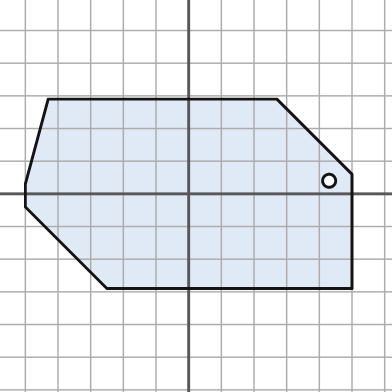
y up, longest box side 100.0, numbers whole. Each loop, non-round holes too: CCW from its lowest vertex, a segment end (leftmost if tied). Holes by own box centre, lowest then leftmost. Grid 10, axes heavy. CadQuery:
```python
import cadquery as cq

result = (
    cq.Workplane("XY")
    .moveTo(-25.0, -29.0)
    .lineTo(50.0, -29.0)
    .lineTo(50.0, 6.0)
    .lineTo(27.0, 29.0)
    .lineTo(-43.0, 29.0)
    .lineTo(-50.0, 3.0)
    .lineTo(-50.0, -4.0)
    .close()
    .moveTo(43.0, 4.0)
    .circle(2.0)
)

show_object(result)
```